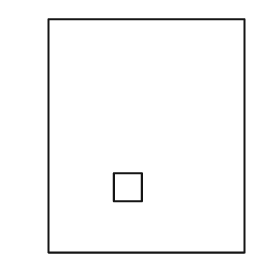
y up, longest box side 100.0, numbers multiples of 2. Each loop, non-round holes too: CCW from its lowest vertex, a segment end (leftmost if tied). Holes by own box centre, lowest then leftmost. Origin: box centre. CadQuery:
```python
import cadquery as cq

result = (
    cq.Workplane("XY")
    .moveTo(-42.0, -50.0)
    .lineTo(42.0, -50.0)
    .lineTo(42.0, 50.0)
    .lineTo(-42.0, 50.0)
    .close()
    .moveTo(-14.0, -28.0)
    .lineTo(-2.0, -28.0)
    .lineTo(-2.0, -16.0)
    .lineTo(-14.0, -16.0)
    .close()
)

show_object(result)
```